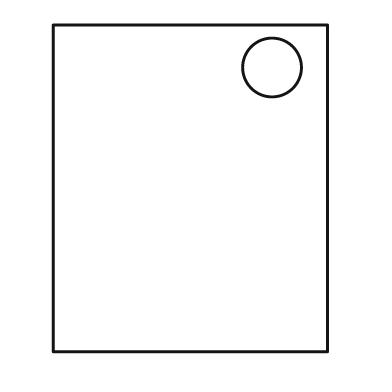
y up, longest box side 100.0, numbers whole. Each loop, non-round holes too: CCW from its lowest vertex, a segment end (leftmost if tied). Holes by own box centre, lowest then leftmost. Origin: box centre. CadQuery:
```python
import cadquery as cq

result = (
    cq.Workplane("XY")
    .moveTo(-42.0, -50.0)
    .lineTo(42.0, -50.0)
    .lineTo(42.0, 50.0)
    .lineTo(-42.0, 50.0)
    .close()
    .moveTo(25.0, 37.0)
    .circle(9.0)
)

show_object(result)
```